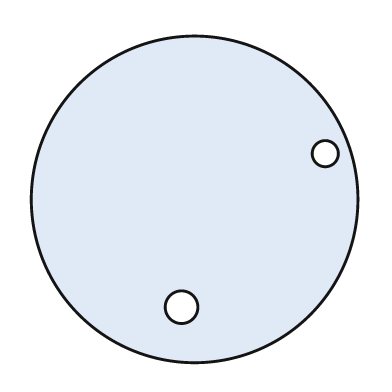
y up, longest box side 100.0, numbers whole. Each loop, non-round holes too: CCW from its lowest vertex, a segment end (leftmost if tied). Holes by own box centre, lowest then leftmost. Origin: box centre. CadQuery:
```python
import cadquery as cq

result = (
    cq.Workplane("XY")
    .moveTo(0.0, 0.0)
    .circle(50.0)
    .moveTo(-4.0, -33.0)
    .circle(5.0)
    .moveTo(40.0, 14.0)
    .circle(4.0)
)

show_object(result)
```